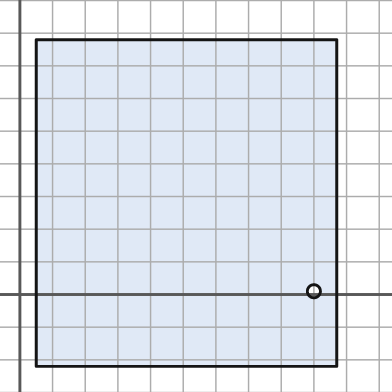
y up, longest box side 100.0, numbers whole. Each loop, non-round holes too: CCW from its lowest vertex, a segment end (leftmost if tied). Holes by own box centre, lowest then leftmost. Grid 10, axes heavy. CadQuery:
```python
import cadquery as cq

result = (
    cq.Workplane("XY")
    .moveTo(5.0, -22.0)
    .lineTo(97.0, -22.0)
    .lineTo(97.0, 78.0)
    .lineTo(5.0, 78.0)
    .close()
    .moveTo(90.0, 1.0)
    .circle(2.0)
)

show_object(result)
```